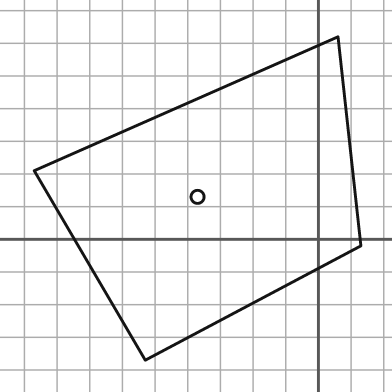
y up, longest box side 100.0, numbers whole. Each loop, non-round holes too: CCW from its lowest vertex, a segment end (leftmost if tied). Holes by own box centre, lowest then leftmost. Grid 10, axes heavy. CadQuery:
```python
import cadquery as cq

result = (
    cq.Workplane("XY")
    .moveTo(-53.0, -37.0)
    .lineTo(13.0, -2.0)
    .lineTo(6.0, 62.0)
    .lineTo(-87.0, 21.0)
    .close()
    .moveTo(-37.0, 13.0)
    .circle(2.0)
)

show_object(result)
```